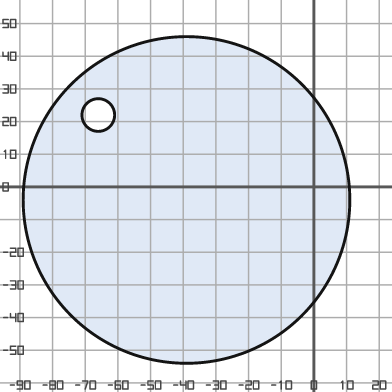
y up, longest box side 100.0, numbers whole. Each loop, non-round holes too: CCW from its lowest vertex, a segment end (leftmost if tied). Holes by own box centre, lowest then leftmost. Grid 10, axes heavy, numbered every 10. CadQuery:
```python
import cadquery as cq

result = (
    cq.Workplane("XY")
    .moveTo(-39.0, -4.0)
    .circle(50.0)
    .moveTo(-66.0, 22.0)
    .circle(5.0)
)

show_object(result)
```